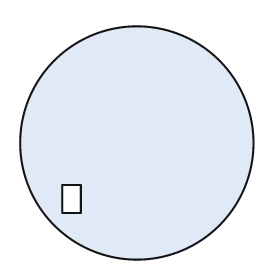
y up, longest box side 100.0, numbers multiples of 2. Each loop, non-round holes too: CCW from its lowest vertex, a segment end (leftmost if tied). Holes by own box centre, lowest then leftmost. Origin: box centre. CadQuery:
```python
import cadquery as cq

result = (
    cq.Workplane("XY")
    .moveTo(0.0, 0.0)
    .circle(50.0)
    .moveTo(-32.0, -30.0)
    .lineTo(-24.0, -30.0)
    .lineTo(-24.0, -18.0)
    .lineTo(-32.0, -18.0)
    .close()
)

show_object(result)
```